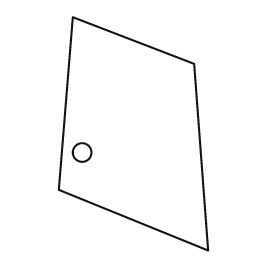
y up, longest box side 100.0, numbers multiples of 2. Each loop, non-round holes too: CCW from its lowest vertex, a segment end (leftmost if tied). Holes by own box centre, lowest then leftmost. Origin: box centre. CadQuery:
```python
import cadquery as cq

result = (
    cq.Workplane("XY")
    .moveTo(32.0, -50.0)
    .lineTo(26.0, 30.0)
    .lineTo(-26.0, 50.0)
    .lineTo(-32.0, -24.0)
    .close()
    .moveTo(-22.0, -8.0)
    .circle(4.0)
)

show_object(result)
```